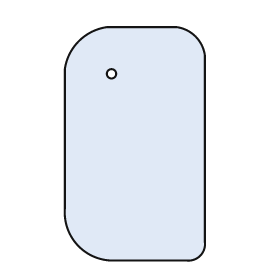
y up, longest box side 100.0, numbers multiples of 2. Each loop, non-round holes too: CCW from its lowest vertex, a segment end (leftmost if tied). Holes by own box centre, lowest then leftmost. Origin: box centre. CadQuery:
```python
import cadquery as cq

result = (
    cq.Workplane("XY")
    .moveTo(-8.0, -50.0)
    .lineTo(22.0, -50.0)
    .threePointArc((28.0, -48.0), (30.0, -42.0))
    .lineTo(30.0, 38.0)
    .threePointArc((26.0, 46.0), (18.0, 50.0))
    .lineTo(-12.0, 50.0)
    .threePointArc((-24.0, 44.0), (-30.0, 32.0))
    .lineTo(-30.0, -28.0)
    .threePointArc((-24.0, -44.0), (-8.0, -50.0))
    .close()
    .moveTo(-10.0, 30.0)
    .circle(2.0)
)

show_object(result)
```